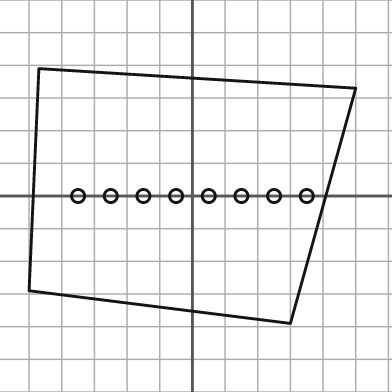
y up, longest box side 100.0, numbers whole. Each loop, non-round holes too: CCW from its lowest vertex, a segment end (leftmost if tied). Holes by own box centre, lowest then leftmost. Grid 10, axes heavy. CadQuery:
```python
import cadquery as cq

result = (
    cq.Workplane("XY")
    .moveTo(30.0, -39.0)
    .lineTo(50.0, 33.0)
    .lineTo(-47.0, 39.0)
    .lineTo(-50.0, -29.0)
    .close()
    .moveTo(-35.0, 0.0)
    .circle(2.0)
    .moveTo(-25.0, 0.0)
    .circle(2.0)
    .moveTo(-15.0, 0.0)
    .circle(2.0)
    .moveTo(-5.0, 0.0)
    .circle(2.0)
    .moveTo(5.0, 0.0)
    .circle(2.0)
    .moveTo(15.0, 0.0)
    .circle(2.0)
    .moveTo(25.0, 0.0)
    .circle(2.0)
    .moveTo(35.0, 0.0)
    .circle(2.0)
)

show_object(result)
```